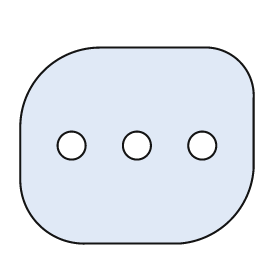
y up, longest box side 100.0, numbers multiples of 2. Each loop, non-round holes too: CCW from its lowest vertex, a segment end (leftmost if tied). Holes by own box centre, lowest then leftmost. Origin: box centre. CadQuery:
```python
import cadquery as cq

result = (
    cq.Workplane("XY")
    .moveTo(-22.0, -42.0)
    .lineTo(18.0, -42.0)
    .threePointArc((40.0, -32.0), (50.0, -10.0))
    .lineTo(50.0, 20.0)
    .threePointArc((44.0, 36.0), (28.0, 42.0))
    .lineTo(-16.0, 42.0)
    .threePointArc((-40.0, 32.0), (-50.0, 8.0))
    .lineTo(-50.0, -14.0)
    .threePointArc((-42.0, -34.0), (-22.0, -42.0))
    .close()
    .moveTo(-28.0, 0.0)
    .circle(6.0)
    .moveTo(0.0, 0.0)
    .circle(6.0)
    .moveTo(28.0, 0.0)
    .circle(6.0)
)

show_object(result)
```